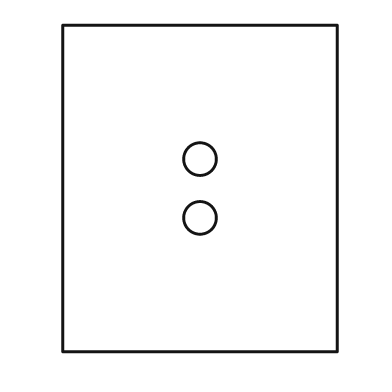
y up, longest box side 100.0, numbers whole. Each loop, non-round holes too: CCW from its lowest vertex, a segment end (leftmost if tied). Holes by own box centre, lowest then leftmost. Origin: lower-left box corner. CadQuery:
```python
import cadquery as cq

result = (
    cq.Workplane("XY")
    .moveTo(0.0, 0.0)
    .lineTo(84.0, 0.0)
    .lineTo(84.0, 100.0)
    .lineTo(0.0, 100.0)
    .close()
    .moveTo(42.0, 41.0)
    .circle(5.0)
    .moveTo(42.0, 59.0)
    .circle(5.0)
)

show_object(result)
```